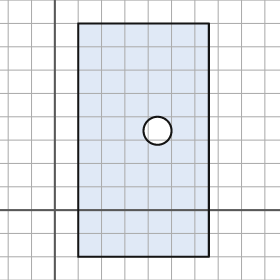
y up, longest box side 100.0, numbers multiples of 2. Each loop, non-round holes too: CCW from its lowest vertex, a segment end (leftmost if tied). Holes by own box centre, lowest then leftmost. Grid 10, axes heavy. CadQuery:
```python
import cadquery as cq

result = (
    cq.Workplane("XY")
    .moveTo(10.0, -20.0)
    .lineTo(66.0, -20.0)
    .lineTo(66.0, 80.0)
    .lineTo(10.0, 80.0)
    .close()
    .moveTo(44.0, 34.0)
    .circle(6.0)
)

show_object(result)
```